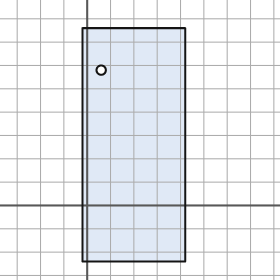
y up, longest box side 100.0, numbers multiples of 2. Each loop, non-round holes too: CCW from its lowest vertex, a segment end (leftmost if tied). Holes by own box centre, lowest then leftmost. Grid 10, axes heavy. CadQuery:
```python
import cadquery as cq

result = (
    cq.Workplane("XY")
    .moveTo(-2.0, -24.0)
    .lineTo(42.0, -24.0)
    .lineTo(42.0, 76.0)
    .lineTo(-2.0, 76.0)
    .close()
    .moveTo(6.0, 58.0)
    .circle(2.0)
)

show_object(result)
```